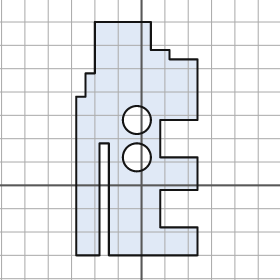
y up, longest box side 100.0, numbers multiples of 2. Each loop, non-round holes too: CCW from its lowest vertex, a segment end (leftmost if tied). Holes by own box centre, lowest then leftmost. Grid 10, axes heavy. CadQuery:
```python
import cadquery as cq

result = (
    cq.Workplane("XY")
    .moveTo(-28.0, -30.0)
    .lineTo(-18.0, -30.0)
    .lineTo(-18.0, 18.0)
    .lineTo(-14.0, 18.0)
    .lineTo(-14.0, -30.0)
    .lineTo(24.0, -30.0)
    .lineTo(24.0, -18.0)
    .lineTo(8.0, -18.0)
    .lineTo(8.0, -2.0)
    .lineTo(24.0, -2.0)
    .lineTo(24.0, 12.0)
    .lineTo(8.0, 12.0)
    .lineTo(8.0, 28.0)
    .lineTo(24.0, 28.0)
    .lineTo(24.0, 54.0)
    .lineTo(12.0, 54.0)
    .lineTo(12.0, 58.0)
    .lineTo(4.0, 58.0)
    .lineTo(4.0, 70.0)
    .lineTo(-20.0, 70.0)
    .lineTo(-20.0, 48.0)
    .lineTo(-24.0, 48.0)
    .lineTo(-24.0, 38.0)
    .lineTo(-28.0, 38.0)
    .close()
    .moveTo(-2.0, 12.0)
    .circle(6.0)
    .moveTo(-2.0, 28.0)
    .circle(6.0)
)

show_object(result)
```